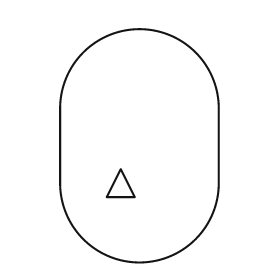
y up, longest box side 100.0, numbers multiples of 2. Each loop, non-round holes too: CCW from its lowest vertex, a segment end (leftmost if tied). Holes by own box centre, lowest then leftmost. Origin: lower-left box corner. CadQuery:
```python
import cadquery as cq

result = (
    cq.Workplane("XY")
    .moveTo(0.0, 34.0)
    .threePointArc((34.0, 0.0), (68.0, 34.0))
    .lineTo(68.0, 66.0)
    .threePointArc((34.0, 100.0), (0.0, 66.0))
    .close()
    .moveTo(20.0, 28.0)
    .lineTo(32.0, 28.0)
    .lineTo(26.0, 40.0)
    .close()
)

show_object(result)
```